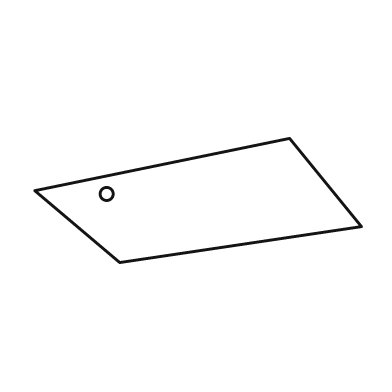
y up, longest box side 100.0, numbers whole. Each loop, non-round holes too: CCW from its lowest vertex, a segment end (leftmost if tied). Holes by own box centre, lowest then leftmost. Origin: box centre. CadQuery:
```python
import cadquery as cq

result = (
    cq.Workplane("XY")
    .moveTo(-24.0, -19.0)
    .lineTo(50.0, -8.0)
    .lineTo(28.0, 19.0)
    .lineTo(-50.0, 3.0)
    .close()
    .moveTo(-28.0, 2.0)
    .circle(2.0)
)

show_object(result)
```